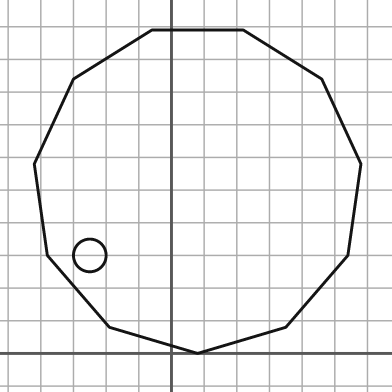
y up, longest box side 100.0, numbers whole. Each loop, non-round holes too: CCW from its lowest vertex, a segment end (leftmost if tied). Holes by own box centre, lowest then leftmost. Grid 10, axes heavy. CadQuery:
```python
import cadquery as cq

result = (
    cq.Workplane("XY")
    .moveTo(8.0, 0.0)
    .lineTo(35.0, 8.0)
    .lineTo(54.0, 30.0)
    .lineTo(58.0, 58.0)
    .lineTo(46.0, 84.0)
    .lineTo(22.0, 99.0)
    .lineTo(-6.0, 99.0)
    .lineTo(-30.0, 84.0)
    .lineTo(-42.0, 58.0)
    .lineTo(-38.0, 30.0)
    .lineTo(-19.0, 8.0)
    .close()
    .moveTo(-25.0, 30.0)
    .circle(5.0)
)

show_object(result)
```